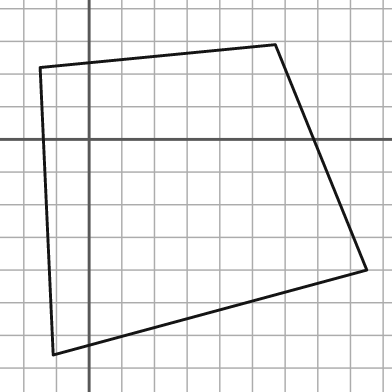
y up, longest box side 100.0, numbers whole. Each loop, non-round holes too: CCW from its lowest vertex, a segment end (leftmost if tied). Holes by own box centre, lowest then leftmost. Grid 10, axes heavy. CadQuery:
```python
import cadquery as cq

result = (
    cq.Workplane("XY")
    .moveTo(-11.0, -66.0)
    .lineTo(85.0, -40.0)
    .lineTo(57.0, 29.0)
    .lineTo(-15.0, 22.0)
    .close()
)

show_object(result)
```